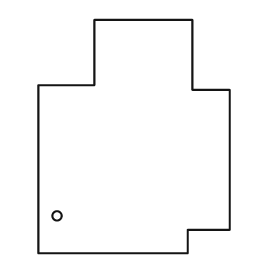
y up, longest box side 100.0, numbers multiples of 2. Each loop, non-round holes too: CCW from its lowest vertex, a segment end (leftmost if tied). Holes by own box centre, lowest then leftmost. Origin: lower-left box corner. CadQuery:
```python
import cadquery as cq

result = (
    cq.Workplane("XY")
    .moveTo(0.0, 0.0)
    .lineTo(64.0, 0.0)
    .lineTo(64.0, 10.0)
    .lineTo(82.0, 10.0)
    .lineTo(82.0, 70.0)
    .lineTo(66.0, 70.0)
    .lineTo(66.0, 100.0)
    .lineTo(24.0, 100.0)
    .lineTo(24.0, 72.0)
    .lineTo(0.0, 72.0)
    .close()
    .moveTo(8.0, 16.0)
    .circle(2.0)
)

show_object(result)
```